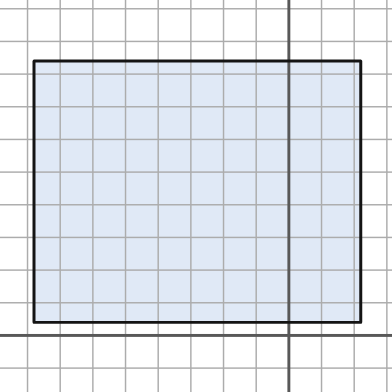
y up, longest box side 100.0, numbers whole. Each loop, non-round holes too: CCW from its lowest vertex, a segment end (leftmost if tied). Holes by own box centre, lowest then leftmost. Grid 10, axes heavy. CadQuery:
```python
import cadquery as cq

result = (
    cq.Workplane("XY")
    .moveTo(-78.0, 4.0)
    .lineTo(22.0, 4.0)
    .lineTo(22.0, 84.0)
    .lineTo(-78.0, 84.0)
    .close()
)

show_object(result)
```